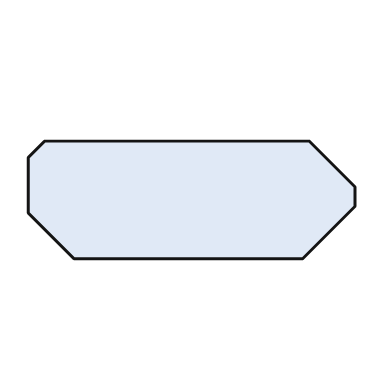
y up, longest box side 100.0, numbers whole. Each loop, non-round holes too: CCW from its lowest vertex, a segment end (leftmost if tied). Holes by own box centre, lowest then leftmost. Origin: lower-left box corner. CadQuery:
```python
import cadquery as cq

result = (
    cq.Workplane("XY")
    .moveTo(14.0, 0.0)
    .lineTo(84.0, 0.0)
    .lineTo(100.0, 16.0)
    .lineTo(100.0, 22.0)
    .lineTo(86.0, 36.0)
    .lineTo(5.0, 36.0)
    .lineTo(0.0, 31.0)
    .lineTo(0.0, 14.0)
    .close()
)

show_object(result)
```